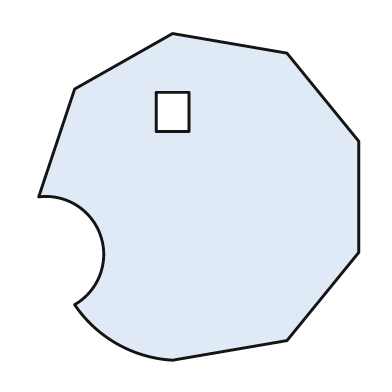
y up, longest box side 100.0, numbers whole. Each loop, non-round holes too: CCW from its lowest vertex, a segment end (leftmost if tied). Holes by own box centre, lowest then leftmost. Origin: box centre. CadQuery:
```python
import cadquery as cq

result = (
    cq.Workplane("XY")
    .moveTo(-8.0, -50.0)
    .lineTo(27.0, -44.0)
    .lineTo(49.0, -17.0)
    .lineTo(49.0, 17.0)
    .lineTo(27.0, 44.0)
    .lineTo(-8.0, 50.0)
    .lineTo(-38.0, 33.0)
    .lineTo(-49.0, 0.0)
    .threePointArc((-30.0, -12.0), (-38.0, -33.0))
    .threePointArc((-25.0, -45.0), (-8.0, -50.0))
    .close()
    .moveTo(-13.0, 20.0)
    .lineTo(-3.0, 20.0)
    .lineTo(-3.0, 32.0)
    .lineTo(-13.0, 32.0)
    .close()
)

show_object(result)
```